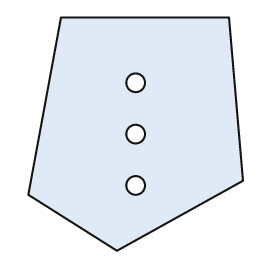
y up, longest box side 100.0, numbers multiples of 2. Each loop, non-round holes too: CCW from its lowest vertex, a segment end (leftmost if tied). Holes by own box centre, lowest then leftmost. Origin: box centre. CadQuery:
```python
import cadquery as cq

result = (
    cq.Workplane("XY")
    .moveTo(-8.0, -50.0)
    .lineTo(46.0, -20.0)
    .lineTo(40.0, 50.0)
    .lineTo(-32.0, 50.0)
    .lineTo(-46.0, -26.0)
    .close()
    .moveTo(0.0, -22.0)
    .circle(4.0)
    .moveTo(0.0, 0.0)
    .circle(4.0)
    .moveTo(0.0, 22.0)
    .circle(4.0)
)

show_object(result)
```